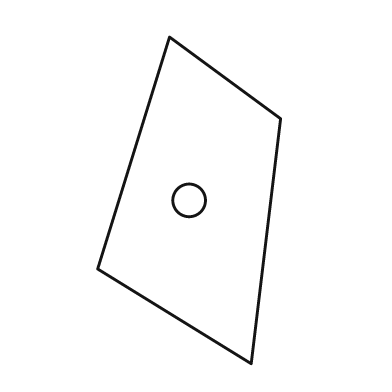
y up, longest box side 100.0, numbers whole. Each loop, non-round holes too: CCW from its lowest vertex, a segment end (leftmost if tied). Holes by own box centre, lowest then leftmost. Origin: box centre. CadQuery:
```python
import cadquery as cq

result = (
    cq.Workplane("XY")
    .moveTo(19.0, -50.0)
    .lineTo(28.0, 25.0)
    .lineTo(-6.0, 50.0)
    .lineTo(-28.0, -21.0)
    .close()
    .moveTo(0.0, 0.0)
    .circle(5.0)
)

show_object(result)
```